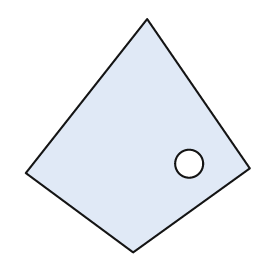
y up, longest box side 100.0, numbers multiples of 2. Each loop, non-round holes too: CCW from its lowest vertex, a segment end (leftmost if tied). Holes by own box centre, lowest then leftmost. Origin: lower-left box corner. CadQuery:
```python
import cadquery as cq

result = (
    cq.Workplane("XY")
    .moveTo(46.0, 0.0)
    .lineTo(96.0, 36.0)
    .lineTo(52.0, 100.0)
    .lineTo(0.0, 34.0)
    .close()
    .moveTo(70.0, 38.0)
    .circle(6.0)
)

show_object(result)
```